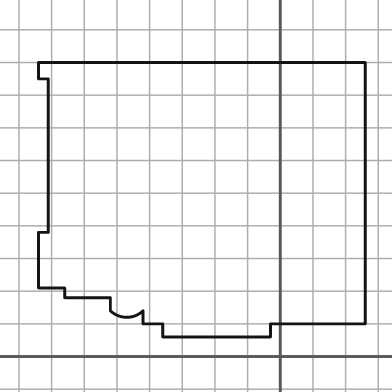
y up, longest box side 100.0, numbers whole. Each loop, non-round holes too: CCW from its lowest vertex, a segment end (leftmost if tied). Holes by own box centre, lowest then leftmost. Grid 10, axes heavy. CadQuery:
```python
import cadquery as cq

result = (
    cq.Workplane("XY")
    .moveTo(-36.0, 6.0)
    .lineTo(-3.0, 6.0)
    .lineTo(-3.0, 10.0)
    .lineTo(26.0, 10.0)
    .lineTo(26.0, 90.0)
    .lineTo(-74.0, 90.0)
    .lineTo(-74.0, 85.0)
    .lineTo(-71.0, 85.0)
    .lineTo(-71.0, 38.0)
    .lineTo(-74.0, 38.0)
    .lineTo(-74.0, 21.0)
    .lineTo(-66.0, 21.0)
    .lineTo(-66.0, 18.0)
    .lineTo(-52.0, 18.0)
    .lineTo(-52.0, 14.0)
    .threePointArc((-47.0, 12.0), (-42.0, 14.0))
    .lineTo(-42.0, 10.0)
    .lineTo(-36.0, 10.0)
    .close()
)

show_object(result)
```